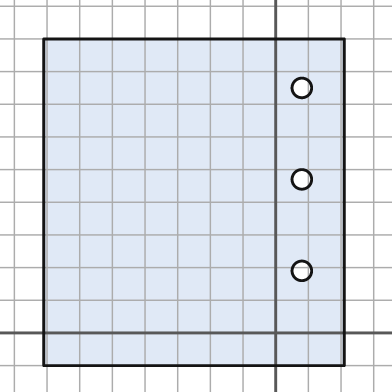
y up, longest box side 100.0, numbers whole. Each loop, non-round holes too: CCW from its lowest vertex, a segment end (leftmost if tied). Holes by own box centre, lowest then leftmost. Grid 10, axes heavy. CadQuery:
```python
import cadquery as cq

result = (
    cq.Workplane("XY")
    .moveTo(-71.0, -10.0)
    .lineTo(21.0, -10.0)
    .lineTo(21.0, 90.0)
    .lineTo(-71.0, 90.0)
    .close()
    .moveTo(8.0, 19.0)
    .circle(3.0)
    .moveTo(8.0, 47.0)
    .circle(3.0)
    .moveTo(8.0, 75.0)
    .circle(3.0)
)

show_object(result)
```